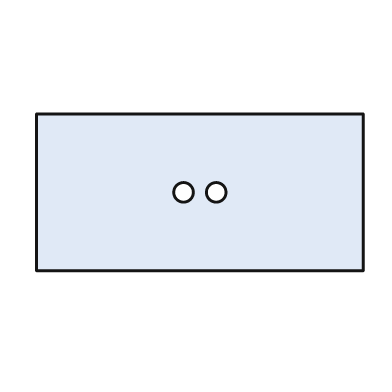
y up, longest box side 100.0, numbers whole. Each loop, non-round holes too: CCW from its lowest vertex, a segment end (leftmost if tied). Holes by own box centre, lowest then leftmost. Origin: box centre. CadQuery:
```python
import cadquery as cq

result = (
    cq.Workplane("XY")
    .moveTo(-50.0, -24.0)
    .lineTo(50.0, -24.0)
    .lineTo(50.0, 24.0)
    .lineTo(-50.0, 24.0)
    .close()
    .moveTo(-5.0, 0.0)
    .circle(3.0)
    .moveTo(5.0, 0.0)
    .circle(3.0)
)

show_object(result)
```